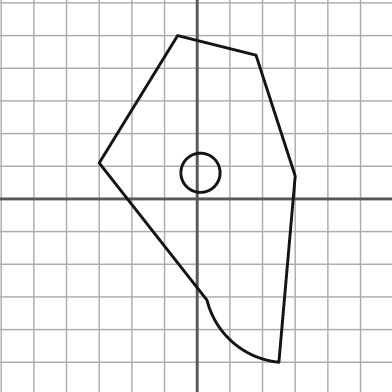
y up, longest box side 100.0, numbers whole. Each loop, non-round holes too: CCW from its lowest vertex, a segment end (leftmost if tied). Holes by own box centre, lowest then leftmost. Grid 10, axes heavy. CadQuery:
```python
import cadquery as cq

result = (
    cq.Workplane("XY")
    .moveTo(25.0, -50.0)
    .lineTo(30.0, 7.0)
    .lineTo(18.0, 44.0)
    .lineTo(-6.0, 50.0)
    .lineTo(-30.0, 11.0)
    .lineTo(3.0, -31.0)
    .threePointArc((11.0, -44.0), (25.0, -50.0))
    .close()
    .moveTo(1.0, 8.0)
    .circle(6.0)
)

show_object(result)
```